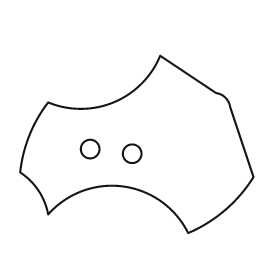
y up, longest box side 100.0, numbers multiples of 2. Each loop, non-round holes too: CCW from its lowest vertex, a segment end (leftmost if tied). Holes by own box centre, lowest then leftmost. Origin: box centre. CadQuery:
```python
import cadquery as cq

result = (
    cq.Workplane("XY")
    .moveTo(22.0, -38.0)
    .threePointArc((38.0, -28.0), (50.0, -14.0))
    .lineTo(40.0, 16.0)
    .threePointArc((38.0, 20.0), (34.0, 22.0))
    .lineTo(10.0, 38.0)
    .threePointArc((-10.0, 18.0), (-38.0, 18.0))
    .threePointArc((-46.0, 4.0), (-50.0, -12.0))
    .threePointArc((-42.0, -20.0), (-38.0, -30.0))
    .threePointArc((-6.0, -18.0), (22.0, -38.0))
    .close()
    .moveTo(-2.0, -4.0)
    .circle(4.0)
    .moveTo(-20.0, -2.0)
    .circle(4.0)
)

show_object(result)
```